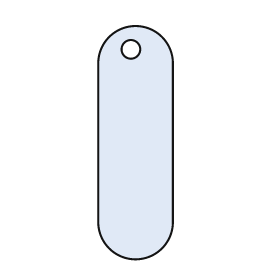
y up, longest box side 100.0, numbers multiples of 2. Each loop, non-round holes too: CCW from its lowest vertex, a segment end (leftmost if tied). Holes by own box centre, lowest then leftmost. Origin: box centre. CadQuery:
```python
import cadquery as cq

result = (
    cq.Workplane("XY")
    .moveTo(-16.0, -34.0)
    .threePointArc((0.0, -50.0), (16.0, -34.0))
    .lineTo(16.0, 34.0)
    .threePointArc((0.0, 50.0), (-16.0, 34.0))
    .close()
    .moveTo(-2.0, 40.0)
    .circle(4.0)
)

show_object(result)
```